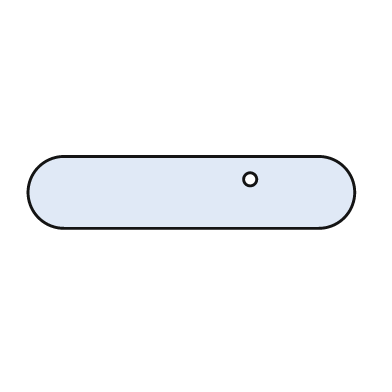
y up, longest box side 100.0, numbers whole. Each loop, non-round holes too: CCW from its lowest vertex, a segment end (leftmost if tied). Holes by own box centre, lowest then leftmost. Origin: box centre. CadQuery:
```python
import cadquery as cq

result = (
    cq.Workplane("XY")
    .moveTo(-39.0, -11.0)
    .lineTo(39.0, -11.0)
    .threePointArc((50.0, 0.0), (39.0, 11.0))
    .lineTo(-39.0, 11.0)
    .threePointArc((-50.0, 0.0), (-39.0, -11.0))
    .close()
    .moveTo(18.0, 4.0)
    .circle(2.0)
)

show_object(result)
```